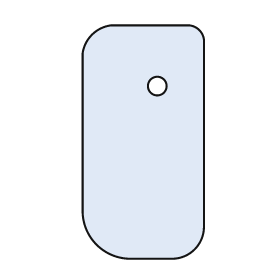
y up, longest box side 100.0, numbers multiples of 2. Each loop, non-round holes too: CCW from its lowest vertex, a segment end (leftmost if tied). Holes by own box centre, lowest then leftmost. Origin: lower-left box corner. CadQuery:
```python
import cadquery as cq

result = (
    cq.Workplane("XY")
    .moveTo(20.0, 0.0)
    .lineTo(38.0, 0.0)
    .threePointArc((48.0, 4.0), (52.0, 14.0))
    .lineTo(52.0, 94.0)
    .threePointArc((50.0, 98.0), (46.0, 100.0))
    .lineTo(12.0, 100.0)
    .threePointArc((4.0, 96.0), (0.0, 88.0))
    .lineTo(0.0, 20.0)
    .threePointArc((6.0, 6.0), (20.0, 0.0))
    .close()
    .moveTo(32.0, 74.0)
    .circle(4.0)
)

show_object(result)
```